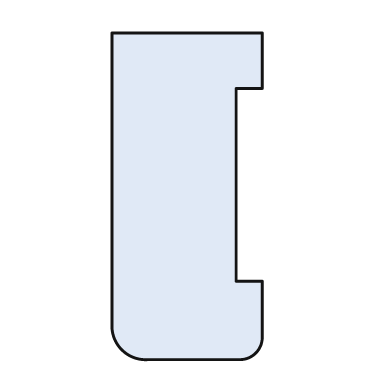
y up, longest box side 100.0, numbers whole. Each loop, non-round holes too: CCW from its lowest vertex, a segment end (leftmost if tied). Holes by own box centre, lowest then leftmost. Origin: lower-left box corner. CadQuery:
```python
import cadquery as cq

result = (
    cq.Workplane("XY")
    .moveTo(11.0, 0.0)
    .lineTo(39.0, 0.0)
    .threePointArc((44.0, 2.0), (46.0, 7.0))
    .lineTo(46.0, 24.0)
    .lineTo(38.0, 24.0)
    .lineTo(38.0, 83.0)
    .lineTo(46.0, 83.0)
    .lineTo(46.0, 100.0)
    .lineTo(0.0, 100.0)
    .lineTo(0.0, 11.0)
    .threePointArc((3.0, 3.0), (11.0, 0.0))
    .close()
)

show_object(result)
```